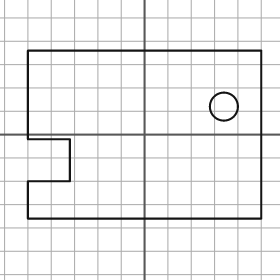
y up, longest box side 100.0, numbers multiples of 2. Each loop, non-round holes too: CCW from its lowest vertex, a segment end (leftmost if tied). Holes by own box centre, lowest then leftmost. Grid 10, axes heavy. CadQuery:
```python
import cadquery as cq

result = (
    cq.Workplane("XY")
    .moveTo(-50.0, -36.0)
    .lineTo(50.0, -36.0)
    .lineTo(50.0, 36.0)
    .lineTo(-50.0, 36.0)
    .lineTo(-50.0, -2.0)
    .lineTo(-32.0, -2.0)
    .lineTo(-32.0, -20.0)
    .lineTo(-50.0, -20.0)
    .close()
    .moveTo(34.0, 12.0)
    .circle(6.0)
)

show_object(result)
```